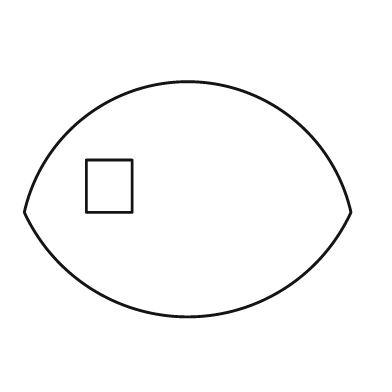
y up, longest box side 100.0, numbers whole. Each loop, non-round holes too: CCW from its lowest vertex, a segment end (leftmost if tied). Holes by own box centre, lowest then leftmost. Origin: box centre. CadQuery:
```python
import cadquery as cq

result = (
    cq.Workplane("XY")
    .moveTo(-50.0, -4.0)
    .threePointArc((0.0, -36.0), (50.0, -4.0))
    .threePointArc((0.0, 36.0), (-50.0, -4.0))
    .close()
    .moveTo(-31.0, -4.0)
    .lineTo(-17.0, -4.0)
    .lineTo(-17.0, 12.0)
    .lineTo(-31.0, 12.0)
    .close()
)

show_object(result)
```